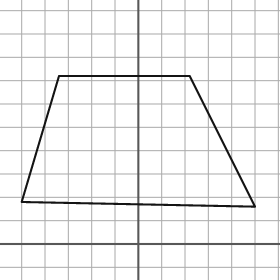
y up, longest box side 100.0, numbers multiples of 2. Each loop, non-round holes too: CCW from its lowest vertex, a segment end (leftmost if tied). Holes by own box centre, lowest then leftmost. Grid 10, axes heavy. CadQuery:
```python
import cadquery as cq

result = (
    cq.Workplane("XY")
    .moveTo(50.0, 16.0)
    .lineTo(22.0, 72.0)
    .lineTo(-34.0, 72.0)
    .lineTo(-50.0, 18.0)
    .close()
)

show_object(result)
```